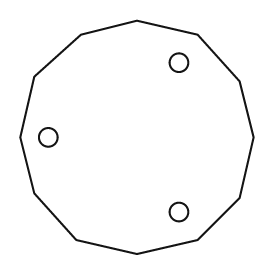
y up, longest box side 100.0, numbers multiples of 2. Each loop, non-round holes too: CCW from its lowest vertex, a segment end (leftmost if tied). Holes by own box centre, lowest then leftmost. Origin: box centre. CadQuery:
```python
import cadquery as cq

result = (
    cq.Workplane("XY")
    .moveTo(0.0, -50.0)
    .lineTo(26.0, -44.0)
    .lineTo(44.0, -26.0)
    .lineTo(50.0, 0.0)
    .lineTo(44.0, 24.0)
    .lineTo(26.0, 44.0)
    .lineTo(0.0, 50.0)
    .lineTo(-24.0, 44.0)
    .lineTo(-44.0, 26.0)
    .lineTo(-50.0, 0.0)
    .lineTo(-44.0, -24.0)
    .lineTo(-26.0, -44.0)
    .close()
    .moveTo(18.0, -32.0)
    .circle(4.0)
    .moveTo(-38.0, 0.0)
    .circle(4.0)
    .moveTo(18.0, 32.0)
    .circle(4.0)
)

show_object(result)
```